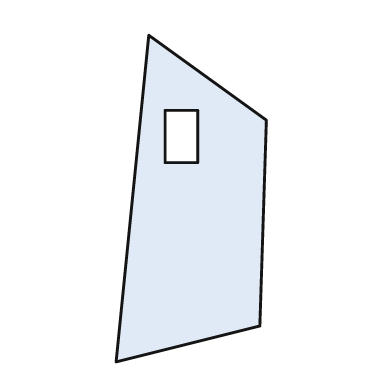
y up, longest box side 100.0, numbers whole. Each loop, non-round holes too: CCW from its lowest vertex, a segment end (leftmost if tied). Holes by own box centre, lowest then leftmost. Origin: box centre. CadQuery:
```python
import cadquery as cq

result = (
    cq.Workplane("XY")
    .moveTo(-23.0, -50.0)
    .lineTo(21.0, -39.0)
    .lineTo(23.0, 24.0)
    .lineTo(-13.0, 50.0)
    .close()
    .moveTo(-8.0, 11.0)
    .lineTo(2.0, 11.0)
    .lineTo(2.0, 27.0)
    .lineTo(-8.0, 27.0)
    .close()
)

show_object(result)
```